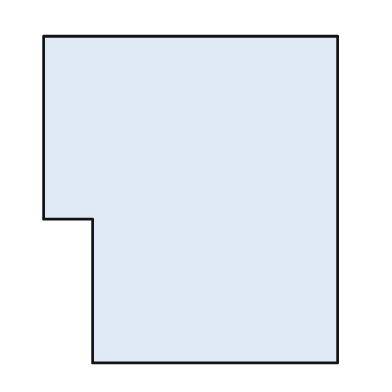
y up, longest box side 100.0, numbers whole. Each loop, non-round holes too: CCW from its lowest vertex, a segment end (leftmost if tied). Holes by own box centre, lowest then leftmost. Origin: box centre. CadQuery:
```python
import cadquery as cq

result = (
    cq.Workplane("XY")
    .moveTo(-30.0, -50.0)
    .lineTo(45.0, -50.0)
    .lineTo(45.0, 50.0)
    .lineTo(-45.0, 50.0)
    .lineTo(-45.0, -6.0)
    .lineTo(-30.0, -6.0)
    .close()
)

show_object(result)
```